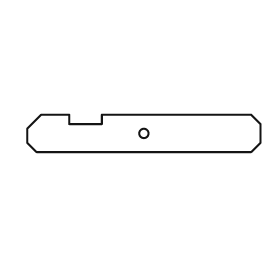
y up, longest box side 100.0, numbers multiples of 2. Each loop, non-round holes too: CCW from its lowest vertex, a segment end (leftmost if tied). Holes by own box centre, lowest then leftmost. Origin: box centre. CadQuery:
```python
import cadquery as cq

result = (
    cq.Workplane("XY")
    .moveTo(-46.0, -8.0)
    .lineTo(46.0, -8.0)
    .lineTo(50.0, -4.0)
    .lineTo(50.0, 4.0)
    .lineTo(46.0, 8.0)
    .lineTo(-18.0, 8.0)
    .lineTo(-18.0, 4.0)
    .lineTo(-32.0, 4.0)
    .lineTo(-32.0, 8.0)
    .lineTo(-44.0, 8.0)
    .lineTo(-50.0, 2.0)
    .lineTo(-50.0, -4.0)
    .close()
    .moveTo(0.0, 0.0)
    .circle(2.0)
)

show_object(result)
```